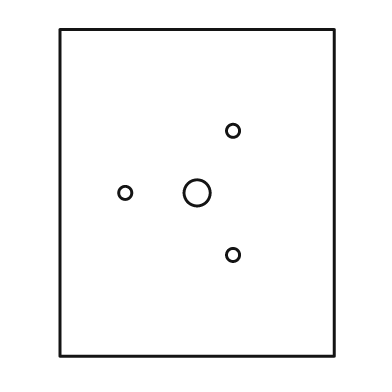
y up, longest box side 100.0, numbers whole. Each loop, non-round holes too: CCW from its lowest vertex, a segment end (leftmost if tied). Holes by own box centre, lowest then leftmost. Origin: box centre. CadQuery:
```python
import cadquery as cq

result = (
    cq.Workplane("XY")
    .moveTo(-42.0, -50.0)
    .lineTo(42.0, -50.0)
    .lineTo(42.0, 50.0)
    .lineTo(-42.0, 50.0)
    .close()
    .moveTo(11.0, -19.0)
    .circle(2.0)
    .moveTo(-22.0, 0.0)
    .circle(2.0)
    .moveTo(0.0, 0.0)
    .circle(4.0)
    .moveTo(11.0, 19.0)
    .circle(2.0)
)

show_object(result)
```